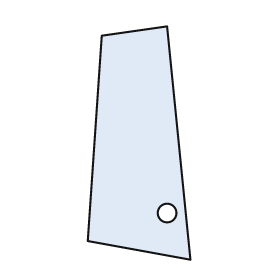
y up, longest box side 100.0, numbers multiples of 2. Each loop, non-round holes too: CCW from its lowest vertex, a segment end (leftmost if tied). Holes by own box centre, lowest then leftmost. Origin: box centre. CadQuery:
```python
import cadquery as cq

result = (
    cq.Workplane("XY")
    .moveTo(22.0, -50.0)
    .lineTo(12.0, 50.0)
    .lineTo(-16.0, 46.0)
    .lineTo(-22.0, -42.0)
    .close()
    .moveTo(12.0, -30.0)
    .circle(4.0)
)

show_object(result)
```